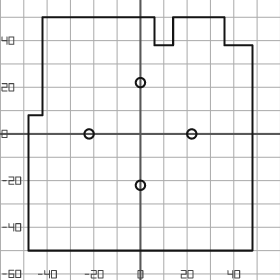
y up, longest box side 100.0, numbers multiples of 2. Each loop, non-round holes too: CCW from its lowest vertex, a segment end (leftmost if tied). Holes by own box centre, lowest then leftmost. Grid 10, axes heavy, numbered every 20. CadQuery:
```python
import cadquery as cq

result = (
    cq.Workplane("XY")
    .moveTo(-48.0, -50.0)
    .lineTo(48.0, -50.0)
    .lineTo(48.0, 38.0)
    .lineTo(36.0, 38.0)
    .lineTo(36.0, 50.0)
    .lineTo(14.0, 50.0)
    .lineTo(14.0, 38.0)
    .lineTo(6.0, 38.0)
    .lineTo(6.0, 50.0)
    .lineTo(-42.0, 50.0)
    .lineTo(-42.0, 8.0)
    .lineTo(-48.0, 8.0)
    .close()
    .moveTo(0.0, -22.0)
    .circle(2.0)
    .moveTo(-22.0, 0.0)
    .circle(2.0)
    .moveTo(22.0, 0.0)
    .circle(2.0)
    .moveTo(0.0, 22.0)
    .circle(2.0)
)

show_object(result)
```